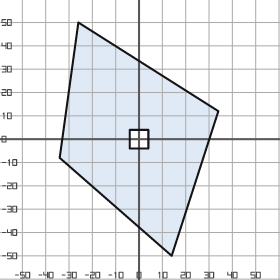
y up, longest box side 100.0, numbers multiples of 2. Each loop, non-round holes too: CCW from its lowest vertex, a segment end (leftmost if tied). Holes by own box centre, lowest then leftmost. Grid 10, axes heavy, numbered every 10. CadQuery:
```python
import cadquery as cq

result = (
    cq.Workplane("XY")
    .moveTo(14.0, -50.0)
    .lineTo(34.0, 12.0)
    .lineTo(-26.0, 50.0)
    .lineTo(-34.0, -8.0)
    .close()
    .moveTo(-4.0, -4.0)
    .lineTo(4.0, -4.0)
    .lineTo(4.0, 4.0)
    .lineTo(-4.0, 4.0)
    .close()
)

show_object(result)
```